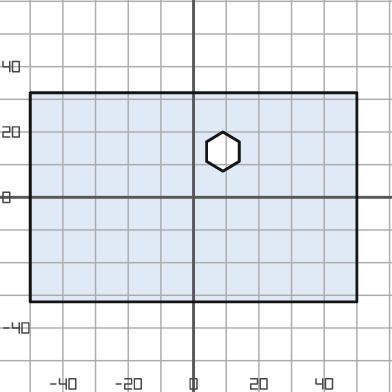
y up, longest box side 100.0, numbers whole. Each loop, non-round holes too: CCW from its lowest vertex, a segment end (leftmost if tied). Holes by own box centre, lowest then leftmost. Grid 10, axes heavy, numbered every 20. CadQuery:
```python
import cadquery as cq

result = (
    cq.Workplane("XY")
    .moveTo(-50.0, -32.0)
    .lineTo(50.0, -32.0)
    .lineTo(50.0, 32.0)
    .lineTo(-50.0, 32.0)
    .close()
    .moveTo(9.0, 8.0)
    .lineTo(14.0, 11.0)
    .lineTo(14.0, 17.0)
    .lineTo(9.0, 20.0)
    .lineTo(4.0, 17.0)
    .lineTo(4.0, 11.0)
    .close()
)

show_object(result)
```